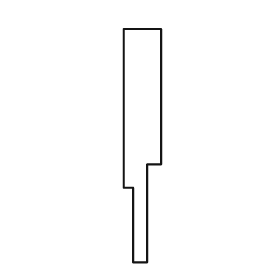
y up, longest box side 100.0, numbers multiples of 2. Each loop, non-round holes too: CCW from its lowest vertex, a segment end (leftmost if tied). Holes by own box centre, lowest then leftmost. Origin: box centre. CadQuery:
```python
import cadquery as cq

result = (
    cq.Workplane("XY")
    .moveTo(-4.0, -50.0)
    .lineTo(2.0, -50.0)
    .lineTo(2.0, -8.0)
    .lineTo(8.0, -8.0)
    .lineTo(8.0, 50.0)
    .lineTo(-8.0, 50.0)
    .lineTo(-8.0, -18.0)
    .lineTo(-4.0, -18.0)
    .close()
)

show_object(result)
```